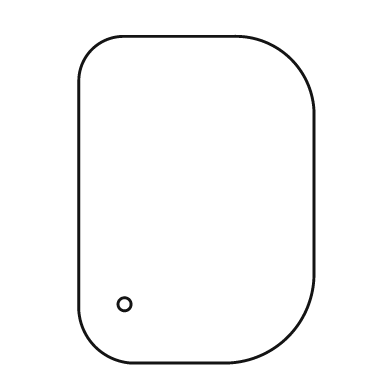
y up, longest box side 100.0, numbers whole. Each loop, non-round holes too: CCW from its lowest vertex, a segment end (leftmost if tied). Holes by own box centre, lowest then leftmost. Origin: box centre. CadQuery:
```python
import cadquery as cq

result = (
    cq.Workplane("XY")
    .moveTo(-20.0, -50.0)
    .lineTo(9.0, -50.0)
    .threePointArc((28.0, -42.0), (36.0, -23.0))
    .lineTo(36.0, 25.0)
    .threePointArc((29.0, 43.0), (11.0, 50.0))
    .lineTo(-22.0, 50.0)
    .threePointArc((-32.0, 46.0), (-36.0, 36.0))
    .lineTo(-36.0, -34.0)
    .threePointArc((-31.0, -45.0), (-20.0, -50.0))
    .close()
    .moveTo(-22.0, -32.0)
    .circle(2.0)
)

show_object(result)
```